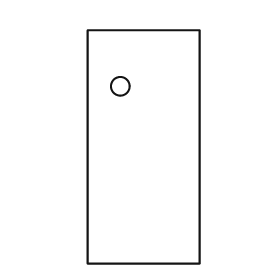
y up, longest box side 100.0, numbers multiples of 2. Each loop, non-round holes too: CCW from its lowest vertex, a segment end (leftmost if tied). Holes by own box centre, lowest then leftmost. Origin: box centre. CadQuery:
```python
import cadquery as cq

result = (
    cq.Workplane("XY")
    .moveTo(-24.0, -50.0)
    .lineTo(24.0, -50.0)
    .lineTo(24.0, 50.0)
    .lineTo(-24.0, 50.0)
    .close()
    .moveTo(-10.0, 26.0)
    .circle(4.0)
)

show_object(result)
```